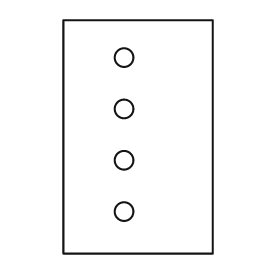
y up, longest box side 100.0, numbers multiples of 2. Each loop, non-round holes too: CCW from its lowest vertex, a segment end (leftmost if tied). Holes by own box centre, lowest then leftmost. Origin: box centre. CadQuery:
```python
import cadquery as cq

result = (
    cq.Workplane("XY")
    .moveTo(-32.0, -50.0)
    .lineTo(32.0, -50.0)
    .lineTo(32.0, 50.0)
    .lineTo(-32.0, 50.0)
    .close()
    .moveTo(-6.0, -32.0)
    .circle(4.0)
    .moveTo(-6.0, -10.0)
    .circle(4.0)
    .moveTo(-6.0, 12.0)
    .circle(4.0)
    .moveTo(-6.0, 34.0)
    .circle(4.0)
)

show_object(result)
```